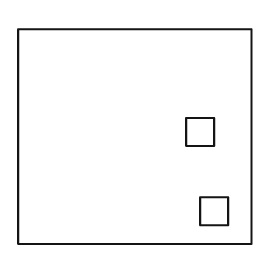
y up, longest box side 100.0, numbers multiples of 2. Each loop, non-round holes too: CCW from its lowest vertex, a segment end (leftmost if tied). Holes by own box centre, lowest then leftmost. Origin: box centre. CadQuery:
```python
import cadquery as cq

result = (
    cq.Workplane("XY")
    .moveTo(-50.0, -46.0)
    .lineTo(50.0, -46.0)
    .lineTo(50.0, 46.0)
    .lineTo(-50.0, 46.0)
    .close()
    .moveTo(28.0, -38.0)
    .lineTo(40.0, -38.0)
    .lineTo(40.0, -26.0)
    .lineTo(28.0, -26.0)
    .close()
    .moveTo(22.0, -4.0)
    .lineTo(34.0, -4.0)
    .lineTo(34.0, 8.0)
    .lineTo(22.0, 8.0)
    .close()
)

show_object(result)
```